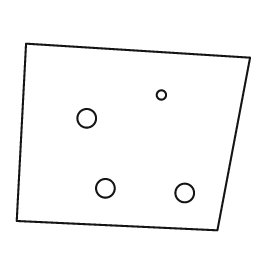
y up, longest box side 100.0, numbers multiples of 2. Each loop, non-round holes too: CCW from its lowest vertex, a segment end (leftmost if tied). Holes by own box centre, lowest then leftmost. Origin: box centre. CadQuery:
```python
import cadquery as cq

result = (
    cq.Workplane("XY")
    .moveTo(36.0, -40.0)
    .lineTo(50.0, 34.0)
    .lineTo(-46.0, 40.0)
    .lineTo(-50.0, -36.0)
    .close()
    .moveTo(22.0, -24.0)
    .circle(4.0)
    .moveTo(-12.0, -22.0)
    .circle(4.0)
    .moveTo(-20.0, 8.0)
    .circle(4.0)
    .moveTo(12.0, 18.0)
    .circle(2.0)
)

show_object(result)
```